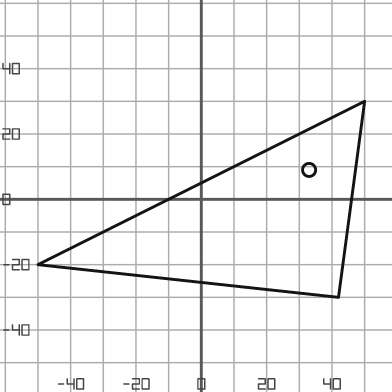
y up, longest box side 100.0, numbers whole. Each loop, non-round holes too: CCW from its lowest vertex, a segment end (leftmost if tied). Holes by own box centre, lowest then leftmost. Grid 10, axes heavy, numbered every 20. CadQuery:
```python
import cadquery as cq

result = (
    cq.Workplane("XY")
    .moveTo(42.0, -30.0)
    .lineTo(50.0, 30.0)
    .lineTo(-50.0, -20.0)
    .close()
    .moveTo(33.0, 9.0)
    .circle(2.0)
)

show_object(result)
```